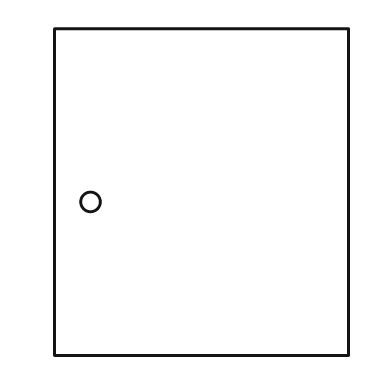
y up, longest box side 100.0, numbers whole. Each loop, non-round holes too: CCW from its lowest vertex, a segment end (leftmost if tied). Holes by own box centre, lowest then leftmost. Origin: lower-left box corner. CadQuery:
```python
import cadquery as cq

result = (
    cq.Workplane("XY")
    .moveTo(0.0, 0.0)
    .lineTo(90.0, 0.0)
    .lineTo(90.0, 100.0)
    .lineTo(0.0, 100.0)
    .close()
    .moveTo(11.0, 47.0)
    .circle(3.0)
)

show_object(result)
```